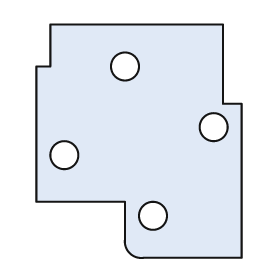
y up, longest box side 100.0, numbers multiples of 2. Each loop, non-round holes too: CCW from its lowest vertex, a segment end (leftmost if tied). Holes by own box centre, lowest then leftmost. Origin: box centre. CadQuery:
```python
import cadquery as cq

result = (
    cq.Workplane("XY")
    .moveTo(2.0, -50.0)
    .lineTo(44.0, -50.0)
    .lineTo(44.0, 16.0)
    .lineTo(36.0, 16.0)
    .lineTo(36.0, 50.0)
    .lineTo(-38.0, 50.0)
    .lineTo(-38.0, 32.0)
    .lineTo(-44.0, 32.0)
    .lineTo(-44.0, -26.0)
    .lineTo(-6.0, -26.0)
    .lineTo(-6.0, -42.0)
    .threePointArc((-4.0, -48.0), (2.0, -50.0))
    .close()
    .moveTo(6.0, -32.0)
    .circle(6.0)
    .moveTo(-32.0, -6.0)
    .circle(6.0)
    .moveTo(32.0, 6.0)
    .circle(6.0)
    .moveTo(-6.0, 32.0)
    .circle(6.0)
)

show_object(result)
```